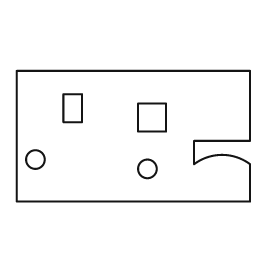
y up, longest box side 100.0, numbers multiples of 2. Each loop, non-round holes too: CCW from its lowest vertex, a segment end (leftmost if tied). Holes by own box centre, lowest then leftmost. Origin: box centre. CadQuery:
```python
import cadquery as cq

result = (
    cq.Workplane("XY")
    .moveTo(-50.0, -28.0)
    .lineTo(50.0, -28.0)
    .lineTo(50.0, -12.0)
    .threePointArc((38.0, -8.0), (26.0, -12.0))
    .lineTo(26.0, -2.0)
    .lineTo(50.0, -2.0)
    .lineTo(50.0, 28.0)
    .lineTo(-50.0, 28.0)
    .close()
    .moveTo(6.0, -14.0)
    .circle(4.0)
    .moveTo(-42.0, -10.0)
    .circle(4.0)
    .moveTo(2.0, 2.0)
    .lineTo(14.0, 2.0)
    .lineTo(14.0, 14.0)
    .lineTo(2.0, 14.0)
    .close()
    .moveTo(-30.0, 6.0)
    .lineTo(-22.0, 6.0)
    .lineTo(-22.0, 18.0)
    .lineTo(-30.0, 18.0)
    .close()
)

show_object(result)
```